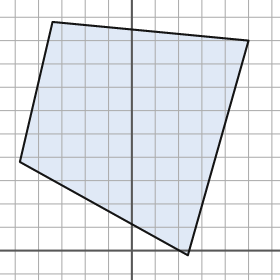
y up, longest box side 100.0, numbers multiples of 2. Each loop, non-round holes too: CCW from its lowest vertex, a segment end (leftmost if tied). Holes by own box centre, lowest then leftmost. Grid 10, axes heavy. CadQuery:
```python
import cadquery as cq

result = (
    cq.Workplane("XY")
    .moveTo(24.0, -2.0)
    .lineTo(50.0, 90.0)
    .lineTo(-34.0, 98.0)
    .lineTo(-48.0, 38.0)
    .close()
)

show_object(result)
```